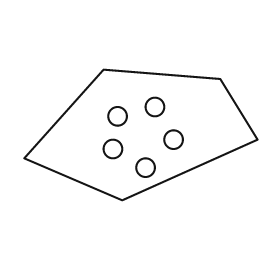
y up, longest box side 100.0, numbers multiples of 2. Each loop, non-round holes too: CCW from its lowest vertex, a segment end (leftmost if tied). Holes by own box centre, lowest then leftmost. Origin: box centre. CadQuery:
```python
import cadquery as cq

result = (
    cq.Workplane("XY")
    .moveTo(-8.0, -28.0)
    .lineTo(50.0, -2.0)
    .lineTo(34.0, 24.0)
    .lineTo(-16.0, 28.0)
    .lineTo(-50.0, -10.0)
    .close()
    .moveTo(2.0, -14.0)
    .circle(4.0)
    .moveTo(-12.0, -6.0)
    .circle(4.0)
    .moveTo(14.0, -2.0)
    .circle(4.0)
    .moveTo(-10.0, 8.0)
    .circle(4.0)
    .moveTo(6.0, 12.0)
    .circle(4.0)
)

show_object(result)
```